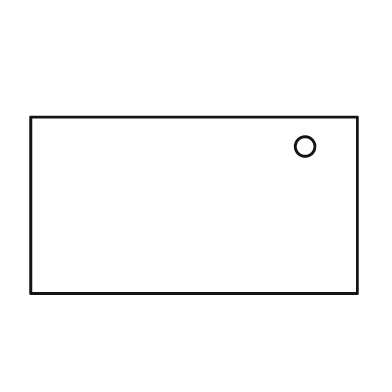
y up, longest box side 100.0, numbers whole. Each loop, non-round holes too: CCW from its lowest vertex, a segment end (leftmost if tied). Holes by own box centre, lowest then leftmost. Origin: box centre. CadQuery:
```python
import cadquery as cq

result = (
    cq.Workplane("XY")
    .moveTo(-50.0, -27.0)
    .lineTo(50.0, -27.0)
    .lineTo(50.0, 27.0)
    .lineTo(-50.0, 27.0)
    .close()
    .moveTo(34.0, 18.0)
    .circle(3.0)
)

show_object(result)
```